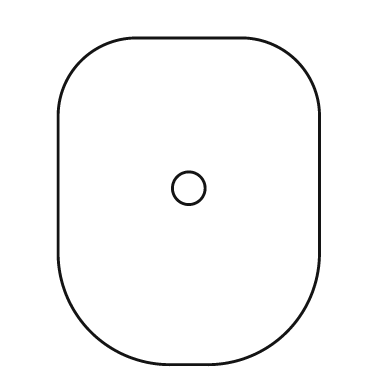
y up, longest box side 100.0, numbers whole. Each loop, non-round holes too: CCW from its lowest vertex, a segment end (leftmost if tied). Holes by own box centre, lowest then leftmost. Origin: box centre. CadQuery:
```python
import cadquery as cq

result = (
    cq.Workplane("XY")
    .moveTo(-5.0, -50.0)
    .lineTo(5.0, -50.0)
    .threePointArc((30.0, -40.0), (40.0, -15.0))
    .lineTo(40.0, 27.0)
    .threePointArc((33.0, 43.0), (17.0, 50.0))
    .lineTo(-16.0, 50.0)
    .threePointArc((-33.0, 43.0), (-40.0, 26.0))
    .lineTo(-40.0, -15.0)
    .threePointArc((-30.0, -40.0), (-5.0, -50.0))
    .close()
    .moveTo(0.0, 4.0)
    .circle(5.0)
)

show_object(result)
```